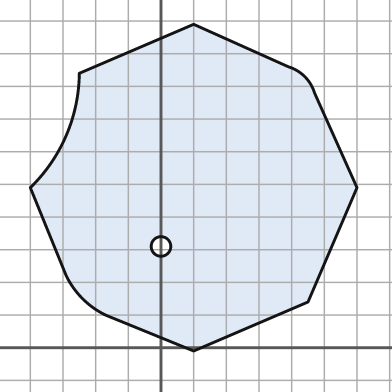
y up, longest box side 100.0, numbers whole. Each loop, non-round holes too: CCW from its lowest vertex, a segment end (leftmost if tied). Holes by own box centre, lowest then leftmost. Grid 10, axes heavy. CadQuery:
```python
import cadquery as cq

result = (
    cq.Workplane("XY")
    .moveTo(10.0, -1.0)
    .lineTo(45.0, 14.0)
    .lineTo(60.0, 49.0)
    .lineTo(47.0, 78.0)
    .threePointArc((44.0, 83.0), (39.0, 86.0))
    .lineTo(10.0, 99.0)
    .lineTo(-25.0, 84.0)
    .threePointArc((-29.0, 65.0), (-40.0, 49.0))
    .lineTo(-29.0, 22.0)
    .threePointArc((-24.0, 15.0), (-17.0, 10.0))
    .close()
    .moveTo(0.0, 31.0)
    .circle(3.0)
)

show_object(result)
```